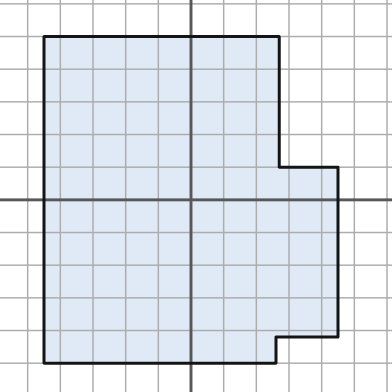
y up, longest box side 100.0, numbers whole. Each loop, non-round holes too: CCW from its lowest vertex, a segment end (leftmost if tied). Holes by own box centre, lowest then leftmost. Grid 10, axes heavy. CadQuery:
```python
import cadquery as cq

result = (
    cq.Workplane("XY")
    .moveTo(-45.0, -50.0)
    .lineTo(26.0, -50.0)
    .lineTo(26.0, -42.0)
    .lineTo(45.0, -42.0)
    .lineTo(45.0, 10.0)
    .lineTo(27.0, 10.0)
    .lineTo(27.0, 50.0)
    .lineTo(-45.0, 50.0)
    .close()
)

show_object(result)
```